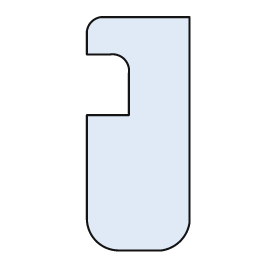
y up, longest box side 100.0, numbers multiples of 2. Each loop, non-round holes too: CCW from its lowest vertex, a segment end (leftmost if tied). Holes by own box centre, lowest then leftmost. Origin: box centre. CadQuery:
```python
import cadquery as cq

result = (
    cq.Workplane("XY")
    .moveTo(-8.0, -50.0)
    .lineTo(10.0, -50.0)
    .threePointArc((18.0, -46.0), (22.0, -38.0))
    .lineTo(22.0, 50.0)
    .lineTo(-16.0, 50.0)
    .threePointArc((-20.0, 48.0), (-22.0, 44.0))
    .lineTo(-22.0, 34.0)
    .lineTo(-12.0, 34.0)
    .threePointArc((-6.0, 32.0), (-4.0, 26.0))
    .lineTo(-4.0, 8.0)
    .lineTo(-22.0, 8.0)
    .lineTo(-22.0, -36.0)
    .threePointArc((-18.0, -46.0), (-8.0, -50.0))
    .close()
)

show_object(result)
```